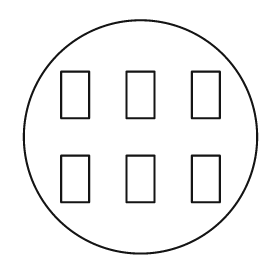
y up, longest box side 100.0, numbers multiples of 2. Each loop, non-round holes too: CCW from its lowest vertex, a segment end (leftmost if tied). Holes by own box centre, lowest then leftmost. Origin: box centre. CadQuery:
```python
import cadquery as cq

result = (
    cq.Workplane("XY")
    .moveTo(0.0, 0.0)
    .circle(50.0)
    .moveTo(-34.0, -28.0)
    .lineTo(-22.0, -28.0)
    .lineTo(-22.0, -8.0)
    .lineTo(-34.0, -8.0)
    .close()
    .moveTo(-6.0, -28.0)
    .lineTo(6.0, -28.0)
    .lineTo(6.0, -8.0)
    .lineTo(-6.0, -8.0)
    .close()
    .moveTo(22.0, -28.0)
    .lineTo(34.0, -28.0)
    .lineTo(34.0, -8.0)
    .lineTo(22.0, -8.0)
    .close()
    .moveTo(-34.0, 8.0)
    .lineTo(-22.0, 8.0)
    .lineTo(-22.0, 28.0)
    .lineTo(-34.0, 28.0)
    .close()
    .moveTo(-6.0, 8.0)
    .lineTo(6.0, 8.0)
    .lineTo(6.0, 28.0)
    .lineTo(-6.0, 28.0)
    .close()
    .moveTo(22.0, 8.0)
    .lineTo(34.0, 8.0)
    .lineTo(34.0, 28.0)
    .lineTo(22.0, 28.0)
    .close()
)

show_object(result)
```